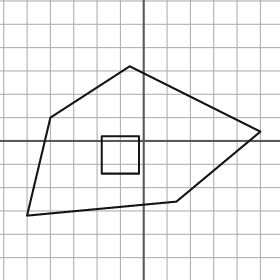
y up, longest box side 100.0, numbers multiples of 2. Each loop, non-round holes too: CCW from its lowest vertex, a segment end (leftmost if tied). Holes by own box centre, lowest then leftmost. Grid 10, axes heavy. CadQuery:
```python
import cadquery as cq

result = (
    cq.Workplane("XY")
    .moveTo(-50.0, -32.0)
    .lineTo(14.0, -26.0)
    .lineTo(50.0, 4.0)
    .lineTo(-6.0, 32.0)
    .lineTo(-40.0, 10.0)
    .close()
    .moveTo(-18.0, -14.0)
    .lineTo(-2.0, -14.0)
    .lineTo(-2.0, 2.0)
    .lineTo(-18.0, 2.0)
    .close()
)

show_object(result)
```